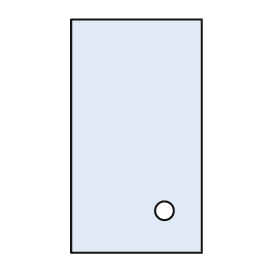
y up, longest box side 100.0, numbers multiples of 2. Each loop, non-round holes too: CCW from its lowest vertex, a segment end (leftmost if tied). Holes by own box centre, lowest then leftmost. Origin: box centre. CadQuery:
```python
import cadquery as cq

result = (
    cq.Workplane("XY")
    .moveTo(-28.0, -50.0)
    .lineTo(28.0, -50.0)
    .lineTo(28.0, 50.0)
    .lineTo(-28.0, 50.0)
    .close()
    .moveTo(12.0, -32.0)
    .circle(4.0)
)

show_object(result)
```